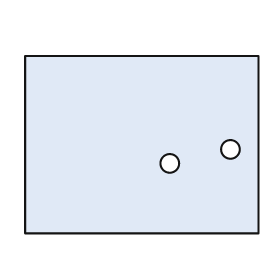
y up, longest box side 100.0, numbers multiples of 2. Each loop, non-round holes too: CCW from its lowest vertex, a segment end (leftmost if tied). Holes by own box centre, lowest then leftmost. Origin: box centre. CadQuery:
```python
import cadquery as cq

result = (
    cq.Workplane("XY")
    .moveTo(-50.0, -38.0)
    .lineTo(50.0, -38.0)
    .lineTo(50.0, 38.0)
    .lineTo(-50.0, 38.0)
    .close()
    .moveTo(12.0, -8.0)
    .circle(4.0)
    .moveTo(38.0, -2.0)
    .circle(4.0)
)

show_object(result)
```